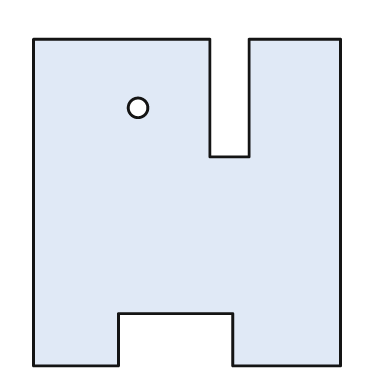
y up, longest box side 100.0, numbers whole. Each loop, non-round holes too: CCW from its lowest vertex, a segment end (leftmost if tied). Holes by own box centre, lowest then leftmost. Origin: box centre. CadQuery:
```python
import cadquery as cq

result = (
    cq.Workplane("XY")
    .moveTo(-47.0, -50.0)
    .lineTo(-21.0, -50.0)
    .lineTo(-21.0, -34.0)
    .lineTo(14.0, -34.0)
    .lineTo(14.0, -50.0)
    .lineTo(47.0, -50.0)
    .lineTo(47.0, 50.0)
    .lineTo(19.0, 50.0)
    .lineTo(19.0, 14.0)
    .lineTo(7.0, 14.0)
    .lineTo(7.0, 50.0)
    .lineTo(-47.0, 50.0)
    .close()
    .moveTo(-15.0, 29.0)
    .circle(3.0)
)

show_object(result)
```